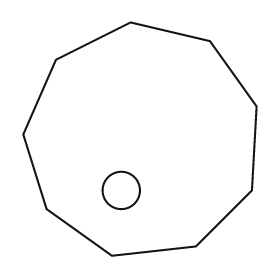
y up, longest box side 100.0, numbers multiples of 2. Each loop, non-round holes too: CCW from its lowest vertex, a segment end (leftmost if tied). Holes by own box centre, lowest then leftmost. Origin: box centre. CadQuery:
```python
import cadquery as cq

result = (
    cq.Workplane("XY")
    .moveTo(-12.0, -50.0)
    .lineTo(24.0, -46.0)
    .lineTo(48.0, -22.0)
    .lineTo(50.0, 14.0)
    .lineTo(30.0, 42.0)
    .lineTo(-4.0, 50.0)
    .lineTo(-36.0, 34.0)
    .lineTo(-50.0, 2.0)
    .lineTo(-40.0, -30.0)
    .close()
    .moveTo(-8.0, -22.0)
    .circle(8.0)
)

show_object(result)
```